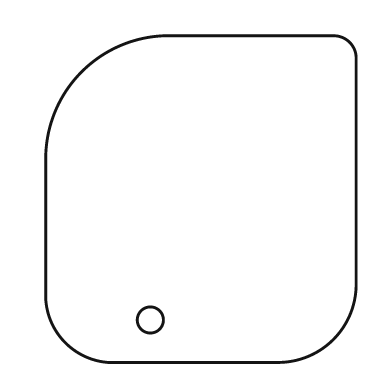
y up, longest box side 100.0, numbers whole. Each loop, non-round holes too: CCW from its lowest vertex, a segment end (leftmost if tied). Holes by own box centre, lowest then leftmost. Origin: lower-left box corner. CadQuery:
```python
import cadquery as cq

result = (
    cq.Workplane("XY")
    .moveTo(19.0, 0.0)
    .lineTo(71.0, 0.0)
    .threePointArc((88.0, 7.0), (95.0, 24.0))
    .lineTo(95.0, 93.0)
    .threePointArc((93.0, 98.0), (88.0, 100.0))
    .lineTo(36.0, 100.0)
    .threePointArc((11.0, 89.0), (0.0, 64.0))
    .lineTo(0.0, 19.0)
    .threePointArc((6.0, 6.0), (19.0, 0.0))
    .close()
    .moveTo(32.0, 13.0)
    .circle(4.0)
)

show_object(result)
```